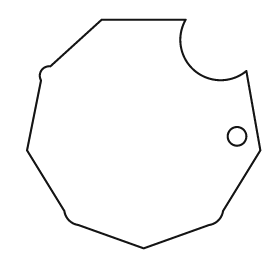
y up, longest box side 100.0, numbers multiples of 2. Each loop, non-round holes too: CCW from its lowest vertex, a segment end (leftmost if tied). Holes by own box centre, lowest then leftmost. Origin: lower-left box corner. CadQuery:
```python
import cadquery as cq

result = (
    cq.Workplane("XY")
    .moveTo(50.0, 0.0)
    .lineTo(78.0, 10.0)
    .threePointArc((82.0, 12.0), (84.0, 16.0))
    .lineTo(100.0, 42.0)
    .lineTo(94.0, 76.0)
    .threePointArc((72.0, 76.0), (68.0, 98.0))
    .lineTo(32.0, 98.0)
    .lineTo(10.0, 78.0)
    .threePointArc((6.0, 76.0), (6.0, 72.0))
    .lineTo(0.0, 42.0)
    .lineTo(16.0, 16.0)
    .threePointArc((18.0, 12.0), (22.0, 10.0))
    .close()
    .moveTo(90.0, 48.0)
    .circle(4.0)
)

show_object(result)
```